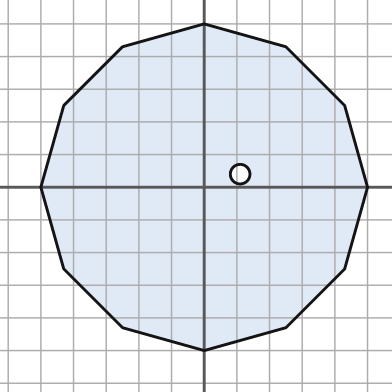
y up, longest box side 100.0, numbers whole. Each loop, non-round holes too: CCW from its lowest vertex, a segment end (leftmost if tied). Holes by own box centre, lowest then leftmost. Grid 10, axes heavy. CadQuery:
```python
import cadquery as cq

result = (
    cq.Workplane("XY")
    .moveTo(0.0, -50.0)
    .lineTo(25.0, -43.0)
    .lineTo(43.0, -25.0)
    .lineTo(50.0, 0.0)
    .lineTo(43.0, 25.0)
    .lineTo(25.0, 43.0)
    .lineTo(0.0, 50.0)
    .lineTo(-25.0, 43.0)
    .lineTo(-43.0, 25.0)
    .lineTo(-50.0, 0.0)
    .lineTo(-43.0, -25.0)
    .lineTo(-25.0, -43.0)
    .close()
    .moveTo(11.0, 4.0)
    .circle(3.0)
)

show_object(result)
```